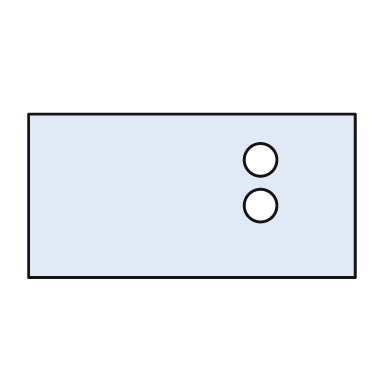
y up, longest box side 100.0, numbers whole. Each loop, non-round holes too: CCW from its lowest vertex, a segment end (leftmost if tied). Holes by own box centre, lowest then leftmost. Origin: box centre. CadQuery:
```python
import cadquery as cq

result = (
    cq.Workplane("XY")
    .moveTo(-50.0, -25.0)
    .lineTo(50.0, -25.0)
    .lineTo(50.0, 25.0)
    .lineTo(-50.0, 25.0)
    .close()
    .moveTo(21.0, -3.0)
    .circle(5.0)
    .moveTo(21.0, 11.0)
    .circle(5.0)
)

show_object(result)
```